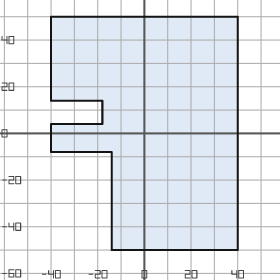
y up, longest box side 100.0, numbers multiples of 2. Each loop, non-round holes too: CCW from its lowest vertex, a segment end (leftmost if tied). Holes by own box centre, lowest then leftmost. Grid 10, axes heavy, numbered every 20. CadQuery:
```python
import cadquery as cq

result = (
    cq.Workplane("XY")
    .moveTo(-14.0, -50.0)
    .lineTo(40.0, -50.0)
    .lineTo(40.0, 50.0)
    .lineTo(-40.0, 50.0)
    .lineTo(-40.0, 14.0)
    .lineTo(-18.0, 14.0)
    .lineTo(-18.0, 4.0)
    .lineTo(-40.0, 4.0)
    .lineTo(-40.0, -8.0)
    .lineTo(-14.0, -8.0)
    .close()
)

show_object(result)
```